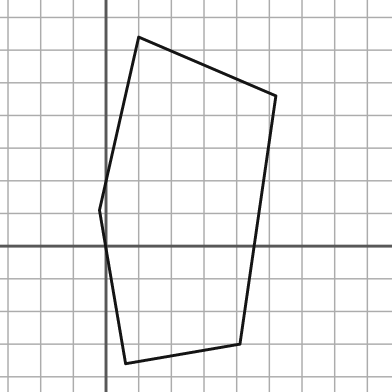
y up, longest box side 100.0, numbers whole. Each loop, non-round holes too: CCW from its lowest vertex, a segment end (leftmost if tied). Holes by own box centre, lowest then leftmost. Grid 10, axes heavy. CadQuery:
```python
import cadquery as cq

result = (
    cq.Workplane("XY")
    .moveTo(6.0, -36.0)
    .lineTo(41.0, -30.0)
    .lineTo(52.0, 46.0)
    .lineTo(10.0, 64.0)
    .lineTo(-2.0, 11.0)
    .close()
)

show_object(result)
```